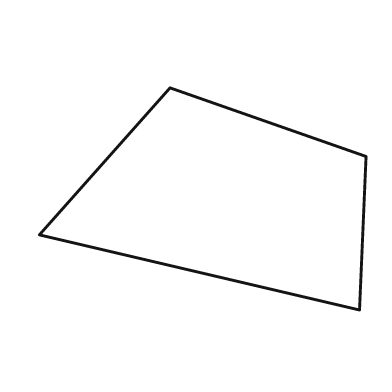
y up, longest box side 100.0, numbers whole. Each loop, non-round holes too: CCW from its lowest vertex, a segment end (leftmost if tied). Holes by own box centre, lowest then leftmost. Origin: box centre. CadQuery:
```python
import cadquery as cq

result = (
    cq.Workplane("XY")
    .moveTo(48.0, -34.0)
    .lineTo(50.0, 13.0)
    .lineTo(-10.0, 34.0)
    .lineTo(-50.0, -11.0)
    .close()
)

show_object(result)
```